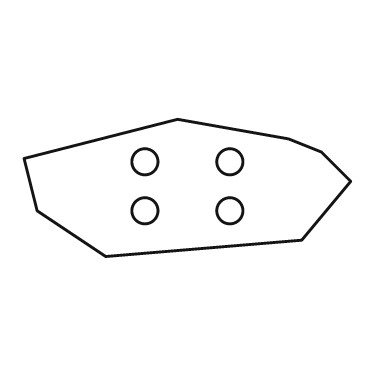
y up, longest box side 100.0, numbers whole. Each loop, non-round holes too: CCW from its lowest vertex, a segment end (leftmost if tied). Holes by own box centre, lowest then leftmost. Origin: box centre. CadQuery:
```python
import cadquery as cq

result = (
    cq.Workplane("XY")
    .moveTo(-25.0, -21.0)
    .lineTo(35.0, -16.0)
    .lineTo(50.0, 2.0)
    .lineTo(41.0, 11.0)
    .lineTo(31.0, 15.0)
    .lineTo(-3.0, 21.0)
    .lineTo(-50.0, 9.0)
    .lineTo(-46.0, -7.0)
    .close()
    .moveTo(-13.0, -7.0)
    .circle(4.0)
    .moveTo(13.0, -7.0)
    .circle(4.0)
    .moveTo(-13.0, 8.0)
    .circle(4.0)
    .moveTo(13.0, 8.0)
    .circle(4.0)
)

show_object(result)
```